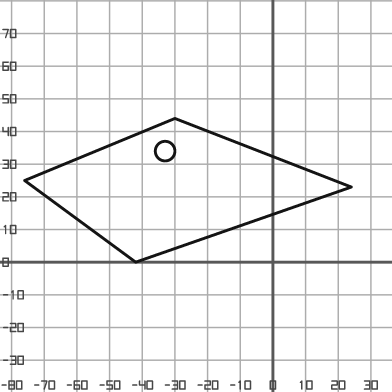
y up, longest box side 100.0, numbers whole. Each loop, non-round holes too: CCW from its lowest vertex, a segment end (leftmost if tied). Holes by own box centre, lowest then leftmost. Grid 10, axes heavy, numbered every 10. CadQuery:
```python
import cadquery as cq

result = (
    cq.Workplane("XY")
    .moveTo(-42.0, 0.0)
    .lineTo(24.0, 23.0)
    .lineTo(-30.0, 44.0)
    .lineTo(-76.0, 25.0)
    .close()
    .moveTo(-33.0, 34.0)
    .circle(3.0)
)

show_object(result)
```